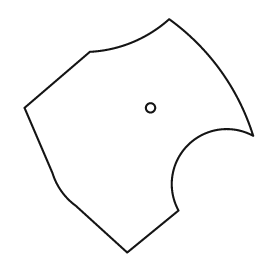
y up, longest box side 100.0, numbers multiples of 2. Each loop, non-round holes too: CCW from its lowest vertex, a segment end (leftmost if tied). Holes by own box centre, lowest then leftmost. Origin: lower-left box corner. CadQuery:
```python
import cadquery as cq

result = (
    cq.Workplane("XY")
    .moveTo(44.0, 0.0)
    .lineTo(66.0, 18.0)
    .threePointArc((70.0, 46.0), (98.0, 50.0))
    .threePointArc((84.0, 78.0), (62.0, 100.0))
    .threePointArc((46.0, 90.0), (28.0, 86.0))
    .lineTo(0.0, 62.0)
    .lineTo(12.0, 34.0)
    .threePointArc((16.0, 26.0), (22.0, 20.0))
    .close()
    .moveTo(54.0, 62.0)
    .circle(2.0)
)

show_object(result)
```